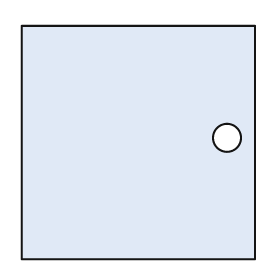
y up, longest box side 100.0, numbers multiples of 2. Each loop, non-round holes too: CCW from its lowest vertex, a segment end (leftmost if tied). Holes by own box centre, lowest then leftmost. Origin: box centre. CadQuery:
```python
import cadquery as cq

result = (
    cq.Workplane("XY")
    .moveTo(-50.0, -50.0)
    .lineTo(50.0, -50.0)
    .lineTo(50.0, 50.0)
    .lineTo(-50.0, 50.0)
    .close()
    .moveTo(38.0, 2.0)
    .circle(6.0)
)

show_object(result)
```